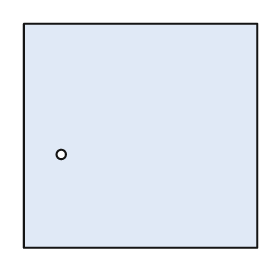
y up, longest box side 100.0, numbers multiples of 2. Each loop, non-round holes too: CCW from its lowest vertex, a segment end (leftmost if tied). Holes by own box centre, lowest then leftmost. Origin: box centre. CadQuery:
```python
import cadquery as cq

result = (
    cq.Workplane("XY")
    .moveTo(-50.0, -48.0)
    .lineTo(50.0, -48.0)
    .lineTo(50.0, 48.0)
    .lineTo(-50.0, 48.0)
    .close()
    .moveTo(-34.0, -8.0)
    .circle(2.0)
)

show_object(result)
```